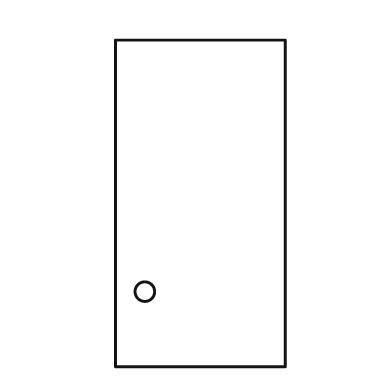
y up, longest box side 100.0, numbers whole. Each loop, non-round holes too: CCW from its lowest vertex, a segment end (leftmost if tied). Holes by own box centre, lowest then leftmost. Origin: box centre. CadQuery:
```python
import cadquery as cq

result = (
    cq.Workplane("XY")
    .moveTo(-26.0, -50.0)
    .lineTo(26.0, -50.0)
    .lineTo(26.0, 50.0)
    .lineTo(-26.0, 50.0)
    .close()
    .moveTo(-17.0, -27.0)
    .circle(3.0)
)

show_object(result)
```